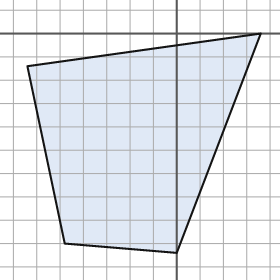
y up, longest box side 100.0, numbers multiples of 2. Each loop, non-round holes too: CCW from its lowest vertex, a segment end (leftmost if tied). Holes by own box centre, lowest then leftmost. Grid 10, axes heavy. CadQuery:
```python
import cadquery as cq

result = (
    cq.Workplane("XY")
    .moveTo(0.0, -94.0)
    .lineTo(36.0, 0.0)
    .lineTo(-64.0, -14.0)
    .lineTo(-48.0, -90.0)
    .close()
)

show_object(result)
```